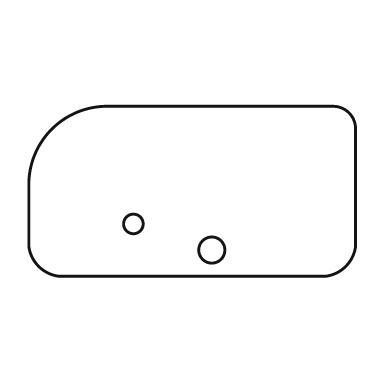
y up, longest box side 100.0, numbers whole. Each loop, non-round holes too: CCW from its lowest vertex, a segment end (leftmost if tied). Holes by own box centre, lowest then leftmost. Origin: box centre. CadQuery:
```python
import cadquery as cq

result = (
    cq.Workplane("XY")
    .moveTo(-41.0, -26.0)
    .lineTo(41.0, -26.0)
    .threePointArc((47.0, -23.0), (50.0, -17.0))
    .lineTo(50.0, 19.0)
    .threePointArc((48.0, 24.0), (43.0, 26.0))
    .lineTo(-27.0, 26.0)
    .threePointArc((-43.0, 19.0), (-50.0, 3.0))
    .lineTo(-50.0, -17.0)
    .threePointArc((-47.0, -23.0), (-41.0, -26.0))
    .close()
    .moveTo(6.0, -18.0)
    .circle(4.0)
    .moveTo(-18.0, -10.0)
    .circle(3.0)
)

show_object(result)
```